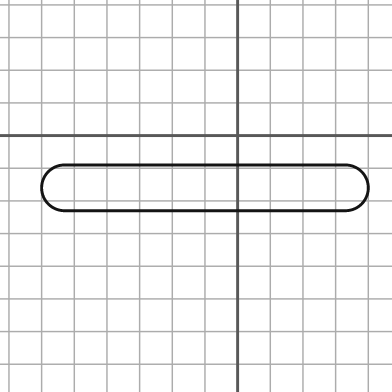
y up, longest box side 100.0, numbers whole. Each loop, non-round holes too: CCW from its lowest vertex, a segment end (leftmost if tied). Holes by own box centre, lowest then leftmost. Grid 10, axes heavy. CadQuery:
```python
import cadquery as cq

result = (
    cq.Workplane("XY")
    .moveTo(-53.0, -23.0)
    .lineTo(33.0, -23.0)
    .threePointArc((40.0, -16.0), (33.0, -9.0))
    .lineTo(-53.0, -9.0)
    .threePointArc((-60.0, -16.0), (-53.0, -23.0))
    .close()
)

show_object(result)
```